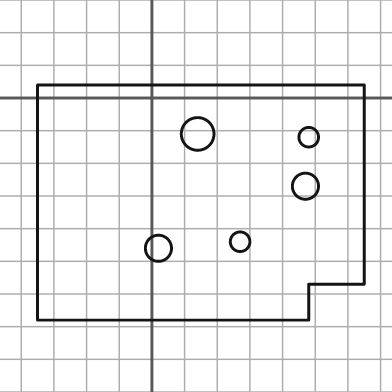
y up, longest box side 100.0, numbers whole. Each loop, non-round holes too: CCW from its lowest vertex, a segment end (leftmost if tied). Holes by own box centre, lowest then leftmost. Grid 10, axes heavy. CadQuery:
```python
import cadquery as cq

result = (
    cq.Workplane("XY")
    .moveTo(-35.0, -68.0)
    .lineTo(48.0, -68.0)
    .lineTo(48.0, -57.0)
    .lineTo(65.0, -57.0)
    .lineTo(65.0, 4.0)
    .lineTo(-35.0, 4.0)
    .close()
    .moveTo(2.0, -46.0)
    .circle(4.0)
    .moveTo(27.0, -44.0)
    .circle(3.0)
    .moveTo(47.0, -27.0)
    .circle(4.0)
    .moveTo(48.0, -12.0)
    .circle(3.0)
    .moveTo(14.0, -11.0)
    .circle(5.0)
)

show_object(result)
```